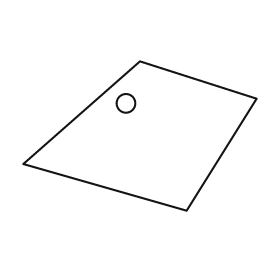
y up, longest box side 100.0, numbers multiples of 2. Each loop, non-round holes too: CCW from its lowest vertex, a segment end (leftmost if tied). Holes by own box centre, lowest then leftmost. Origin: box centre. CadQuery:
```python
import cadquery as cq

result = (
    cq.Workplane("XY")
    .moveTo(20.0, -32.0)
    .lineTo(50.0, 16.0)
    .lineTo(0.0, 32.0)
    .lineTo(-50.0, -12.0)
    .close()
    .moveTo(-6.0, 14.0)
    .circle(4.0)
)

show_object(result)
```